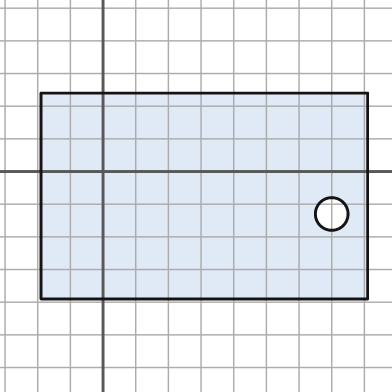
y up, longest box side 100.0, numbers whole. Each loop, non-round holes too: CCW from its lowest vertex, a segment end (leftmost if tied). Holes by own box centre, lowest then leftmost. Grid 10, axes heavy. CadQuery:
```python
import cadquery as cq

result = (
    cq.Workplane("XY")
    .moveTo(-19.0, -39.0)
    .lineTo(81.0, -39.0)
    .lineTo(81.0, 24.0)
    .lineTo(-19.0, 24.0)
    .close()
    .moveTo(70.0, -13.0)
    .circle(5.0)
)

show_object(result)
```